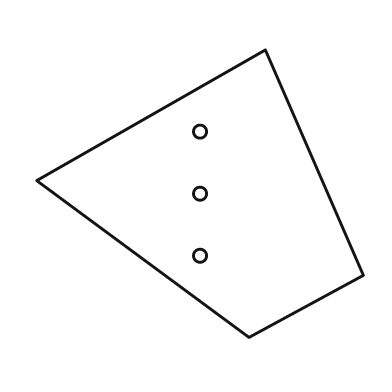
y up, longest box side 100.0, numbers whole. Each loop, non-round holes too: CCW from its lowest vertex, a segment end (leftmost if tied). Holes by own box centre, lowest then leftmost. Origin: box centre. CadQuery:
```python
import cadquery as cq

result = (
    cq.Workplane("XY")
    .moveTo(15.0, -44.0)
    .lineTo(50.0, -25.0)
    .lineTo(20.0, 44.0)
    .lineTo(-50.0, 4.0)
    .close()
    .moveTo(0.0, -19.0)
    .circle(2.0)
    .moveTo(0.0, 0.0)
    .circle(2.0)
    .moveTo(0.0, 19.0)
    .circle(2.0)
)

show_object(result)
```